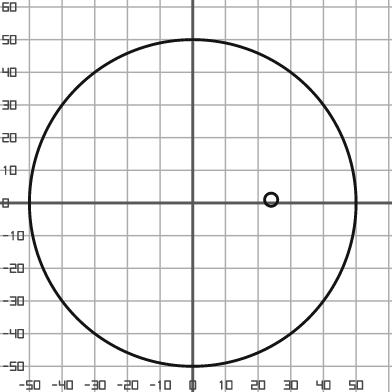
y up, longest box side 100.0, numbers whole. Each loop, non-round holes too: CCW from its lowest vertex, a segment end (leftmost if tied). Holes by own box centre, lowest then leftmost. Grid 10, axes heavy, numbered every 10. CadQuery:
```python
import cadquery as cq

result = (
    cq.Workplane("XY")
    .moveTo(0.0, 0.0)
    .circle(50.0)
    .moveTo(24.0, 1.0)
    .circle(2.0)
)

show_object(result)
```